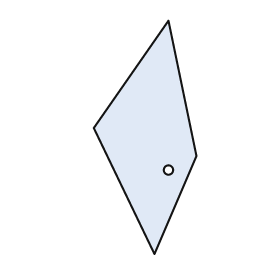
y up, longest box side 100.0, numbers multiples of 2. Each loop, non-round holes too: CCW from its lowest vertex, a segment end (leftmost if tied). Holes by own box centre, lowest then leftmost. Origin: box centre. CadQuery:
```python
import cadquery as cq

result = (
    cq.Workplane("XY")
    .moveTo(4.0, -50.0)
    .lineTo(22.0, -8.0)
    .lineTo(10.0, 50.0)
    .lineTo(-22.0, 4.0)
    .close()
    .moveTo(10.0, -14.0)
    .circle(2.0)
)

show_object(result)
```